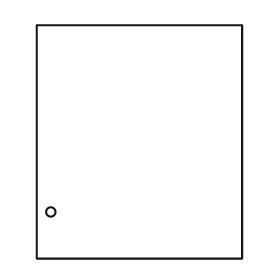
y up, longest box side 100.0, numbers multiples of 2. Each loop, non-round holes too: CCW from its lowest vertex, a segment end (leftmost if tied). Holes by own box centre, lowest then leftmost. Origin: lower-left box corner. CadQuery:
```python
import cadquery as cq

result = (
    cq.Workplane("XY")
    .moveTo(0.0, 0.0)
    .lineTo(88.0, 0.0)
    .lineTo(88.0, 100.0)
    .lineTo(0.0, 100.0)
    .close()
    .moveTo(6.0, 20.0)
    .circle(2.0)
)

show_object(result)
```